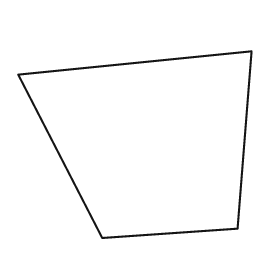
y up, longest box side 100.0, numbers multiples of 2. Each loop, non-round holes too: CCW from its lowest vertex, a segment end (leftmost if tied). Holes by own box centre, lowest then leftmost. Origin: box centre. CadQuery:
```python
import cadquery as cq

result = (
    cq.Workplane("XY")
    .moveTo(-14.0, -40.0)
    .lineTo(44.0, -36.0)
    .lineTo(50.0, 40.0)
    .lineTo(-50.0, 30.0)
    .close()
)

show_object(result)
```